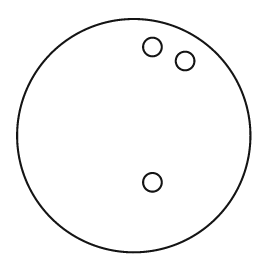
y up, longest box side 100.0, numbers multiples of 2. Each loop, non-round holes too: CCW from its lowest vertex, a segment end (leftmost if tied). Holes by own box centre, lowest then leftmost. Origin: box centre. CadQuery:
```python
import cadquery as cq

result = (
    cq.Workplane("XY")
    .moveTo(0.0, 0.0)
    .circle(50.0)
    .moveTo(8.0, -20.0)
    .circle(4.0)
    .moveTo(22.0, 32.0)
    .circle(4.0)
    .moveTo(8.0, 38.0)
    .circle(4.0)
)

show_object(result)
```